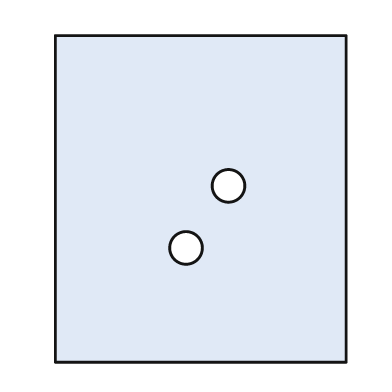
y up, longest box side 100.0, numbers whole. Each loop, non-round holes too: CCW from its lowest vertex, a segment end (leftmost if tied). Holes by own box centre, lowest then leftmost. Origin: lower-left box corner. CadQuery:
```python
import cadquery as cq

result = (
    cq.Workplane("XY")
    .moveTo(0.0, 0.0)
    .lineTo(89.0, 0.0)
    .lineTo(89.0, 100.0)
    .lineTo(0.0, 100.0)
    .close()
    .moveTo(40.0, 35.0)
    .circle(5.0)
    .moveTo(53.0, 54.0)
    .circle(5.0)
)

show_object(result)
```